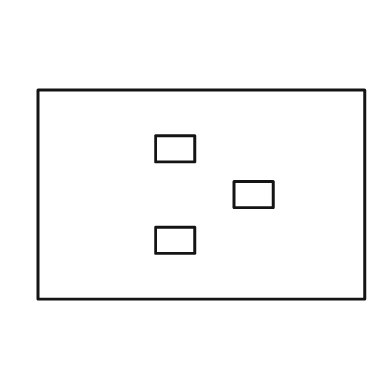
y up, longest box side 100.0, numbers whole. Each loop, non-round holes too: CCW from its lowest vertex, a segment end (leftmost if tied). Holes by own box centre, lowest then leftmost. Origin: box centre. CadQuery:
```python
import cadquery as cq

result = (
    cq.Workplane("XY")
    .moveTo(-50.0, -32.0)
    .lineTo(50.0, -32.0)
    .lineTo(50.0, 32.0)
    .lineTo(-50.0, 32.0)
    .close()
    .moveTo(-14.0, -18.0)
    .lineTo(-2.0, -18.0)
    .lineTo(-2.0, -10.0)
    .lineTo(-14.0, -10.0)
    .close()
    .moveTo(10.0, -4.0)
    .lineTo(22.0, -4.0)
    .lineTo(22.0, 4.0)
    .lineTo(10.0, 4.0)
    .close()
    .moveTo(-14.0, 10.0)
    .lineTo(-2.0, 10.0)
    .lineTo(-2.0, 18.0)
    .lineTo(-14.0, 18.0)
    .close()
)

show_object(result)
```